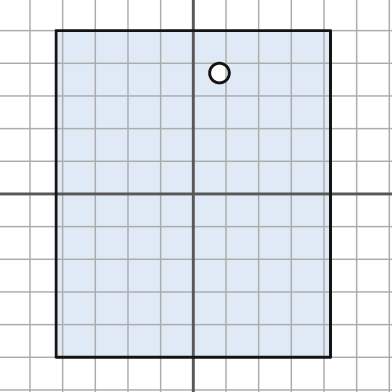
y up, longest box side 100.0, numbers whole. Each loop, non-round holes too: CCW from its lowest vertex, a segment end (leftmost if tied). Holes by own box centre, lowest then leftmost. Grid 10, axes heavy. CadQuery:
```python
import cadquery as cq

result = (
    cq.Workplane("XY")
    .moveTo(-42.0, -50.0)
    .lineTo(42.0, -50.0)
    .lineTo(42.0, 50.0)
    .lineTo(-42.0, 50.0)
    .close()
    .moveTo(8.0, 37.0)
    .circle(3.0)
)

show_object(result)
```